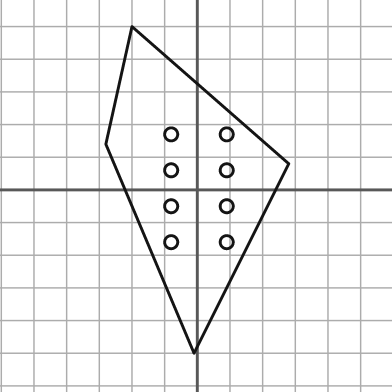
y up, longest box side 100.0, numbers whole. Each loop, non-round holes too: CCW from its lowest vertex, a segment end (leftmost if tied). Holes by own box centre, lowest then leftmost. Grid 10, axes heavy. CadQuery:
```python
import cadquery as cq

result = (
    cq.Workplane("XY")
    .moveTo(-1.0, -50.0)
    .lineTo(28.0, 8.0)
    .lineTo(-20.0, 50.0)
    .lineTo(-28.0, 14.0)
    .close()
    .moveTo(-8.0, -16.0)
    .circle(2.0)
    .moveTo(9.0, -16.0)
    .circle(2.0)
    .moveTo(-8.0, -5.0)
    .circle(2.0)
    .moveTo(9.0, -5.0)
    .circle(2.0)
    .moveTo(-8.0, 6.0)
    .circle(2.0)
    .moveTo(9.0, 6.0)
    .circle(2.0)
    .moveTo(-8.0, 17.0)
    .circle(2.0)
    .moveTo(9.0, 17.0)
    .circle(2.0)
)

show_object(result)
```